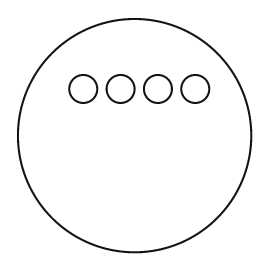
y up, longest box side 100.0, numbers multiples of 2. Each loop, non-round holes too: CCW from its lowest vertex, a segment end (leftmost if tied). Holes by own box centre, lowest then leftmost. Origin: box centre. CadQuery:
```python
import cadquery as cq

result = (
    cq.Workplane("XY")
    .moveTo(0.0, 0.0)
    .circle(50.0)
    .moveTo(-22.0, 20.0)
    .circle(6.0)
    .moveTo(-6.0, 20.0)
    .circle(6.0)
    .moveTo(10.0, 20.0)
    .circle(6.0)
    .moveTo(26.0, 20.0)
    .circle(6.0)
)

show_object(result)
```